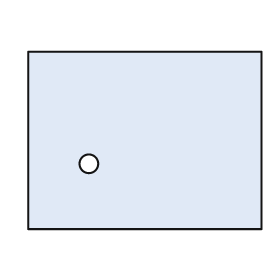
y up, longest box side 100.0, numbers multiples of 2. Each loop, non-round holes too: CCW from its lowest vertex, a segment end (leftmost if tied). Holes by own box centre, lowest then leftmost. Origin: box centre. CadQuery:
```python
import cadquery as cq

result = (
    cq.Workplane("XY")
    .moveTo(-50.0, -38.0)
    .lineTo(50.0, -38.0)
    .lineTo(50.0, 38.0)
    .lineTo(-50.0, 38.0)
    .close()
    .moveTo(-24.0, -10.0)
    .circle(4.0)
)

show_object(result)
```